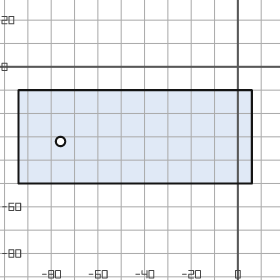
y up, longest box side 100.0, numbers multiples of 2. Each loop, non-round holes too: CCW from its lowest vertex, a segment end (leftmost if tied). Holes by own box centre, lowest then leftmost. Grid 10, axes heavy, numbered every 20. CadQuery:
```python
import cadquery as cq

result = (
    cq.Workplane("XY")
    .moveTo(-94.0, -50.0)
    .lineTo(6.0, -50.0)
    .lineTo(6.0, -10.0)
    .lineTo(-94.0, -10.0)
    .close()
    .moveTo(-76.0, -32.0)
    .circle(2.0)
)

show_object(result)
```